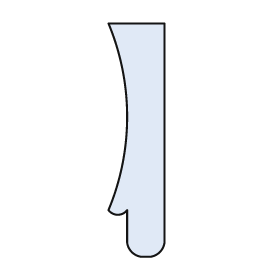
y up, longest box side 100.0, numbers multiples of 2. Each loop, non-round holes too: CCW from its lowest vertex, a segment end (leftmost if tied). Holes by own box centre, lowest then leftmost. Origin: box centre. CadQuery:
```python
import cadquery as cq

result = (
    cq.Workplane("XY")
    .moveTo(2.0, -50.0)
    .lineTo(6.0, -50.0)
    .threePointArc((10.0, -48.0), (12.0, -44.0))
    .lineTo(12.0, 50.0)
    .lineTo(-12.0, 50.0)
    .threePointArc((-4.0, 10.0), (-12.0, -30.0))
    .threePointArc((-8.0, -32.0), (-4.0, -30.0))
    .lineTo(-4.0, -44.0)
    .threePointArc((-2.0, -48.0), (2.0, -50.0))
    .close()
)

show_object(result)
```